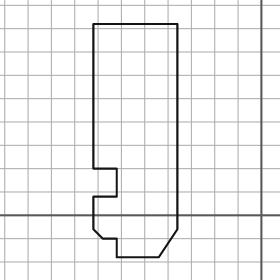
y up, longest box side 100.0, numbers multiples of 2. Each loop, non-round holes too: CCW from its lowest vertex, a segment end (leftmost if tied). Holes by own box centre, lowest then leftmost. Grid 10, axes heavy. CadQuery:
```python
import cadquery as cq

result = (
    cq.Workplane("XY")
    .moveTo(-62.0, -18.0)
    .lineTo(-44.0, -18.0)
    .lineTo(-36.0, -6.0)
    .lineTo(-36.0, 82.0)
    .lineTo(-72.0, 82.0)
    .lineTo(-72.0, 20.0)
    .lineTo(-62.0, 20.0)
    .lineTo(-62.0, 8.0)
    .lineTo(-72.0, 8.0)
    .lineTo(-72.0, -6.0)
    .lineTo(-68.0, -10.0)
    .lineTo(-62.0, -10.0)
    .close()
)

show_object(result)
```